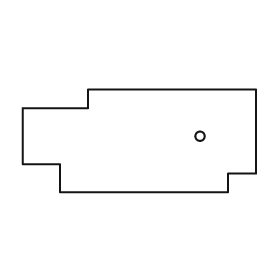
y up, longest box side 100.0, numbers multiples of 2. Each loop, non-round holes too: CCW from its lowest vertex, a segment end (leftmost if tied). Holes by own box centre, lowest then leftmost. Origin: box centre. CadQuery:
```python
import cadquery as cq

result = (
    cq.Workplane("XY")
    .moveTo(-34.0, -22.0)
    .lineTo(38.0, -22.0)
    .lineTo(38.0, -14.0)
    .lineTo(50.0, -14.0)
    .lineTo(50.0, 22.0)
    .lineTo(-22.0, 22.0)
    .lineTo(-22.0, 14.0)
    .lineTo(-50.0, 14.0)
    .lineTo(-50.0, -10.0)
    .lineTo(-34.0, -10.0)
    .close()
    .moveTo(26.0, 2.0)
    .circle(2.0)
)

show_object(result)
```